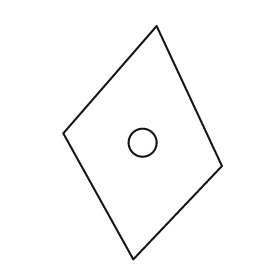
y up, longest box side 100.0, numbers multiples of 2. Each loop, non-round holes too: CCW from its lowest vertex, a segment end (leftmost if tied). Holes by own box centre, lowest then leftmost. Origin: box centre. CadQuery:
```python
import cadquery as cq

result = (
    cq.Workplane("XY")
    .moveTo(-4.0, -50.0)
    .lineTo(34.0, -10.0)
    .lineTo(6.0, 50.0)
    .lineTo(-34.0, 4.0)
    .close()
    .moveTo(0.0, 0.0)
    .circle(6.0)
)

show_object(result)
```